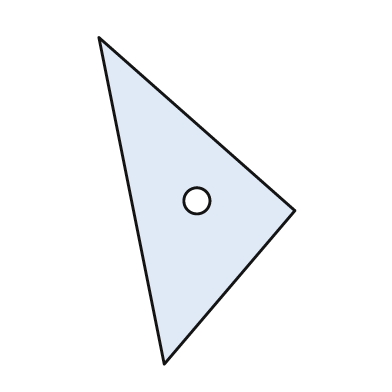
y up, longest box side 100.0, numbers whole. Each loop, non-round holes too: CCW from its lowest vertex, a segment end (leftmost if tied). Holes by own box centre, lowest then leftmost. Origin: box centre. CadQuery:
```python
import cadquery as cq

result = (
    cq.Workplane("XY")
    .moveTo(-10.0, -50.0)
    .lineTo(30.0, -3.0)
    .lineTo(-30.0, 50.0)
    .close()
    .moveTo(0.0, 0.0)
    .circle(4.0)
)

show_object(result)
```